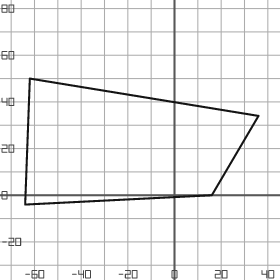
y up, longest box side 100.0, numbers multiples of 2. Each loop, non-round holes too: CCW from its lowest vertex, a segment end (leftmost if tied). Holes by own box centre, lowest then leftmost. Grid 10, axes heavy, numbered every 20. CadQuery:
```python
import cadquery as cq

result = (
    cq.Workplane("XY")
    .moveTo(-64.0, -4.0)
    .lineTo(16.0, 0.0)
    .lineTo(36.0, 34.0)
    .lineTo(-62.0, 50.0)
    .close()
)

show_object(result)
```